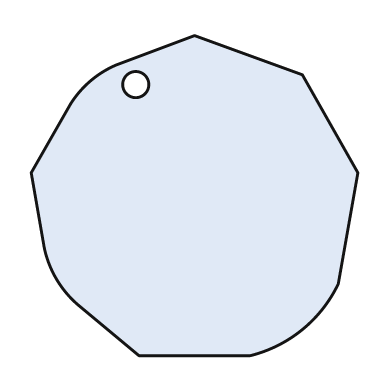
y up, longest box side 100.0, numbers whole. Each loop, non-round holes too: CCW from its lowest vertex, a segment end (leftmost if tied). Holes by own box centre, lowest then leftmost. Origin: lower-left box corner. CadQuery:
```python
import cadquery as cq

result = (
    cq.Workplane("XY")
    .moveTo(33.0, 0.0)
    .lineTo(67.0, 0.0)
    .threePointArc((83.0, 8.0), (94.0, 22.0))
    .lineTo(100.0, 56.0)
    .lineTo(83.0, 86.0)
    .lineTo(50.0, 98.0)
    .lineTo(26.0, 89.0)
    .threePointArc((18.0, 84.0), (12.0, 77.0))
    .lineTo(0.0, 56.0)
    .lineTo(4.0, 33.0)
    .threePointArc((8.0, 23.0), (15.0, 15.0))
    .close()
    .moveTo(32.0, 83.0)
    .circle(4.0)
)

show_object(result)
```